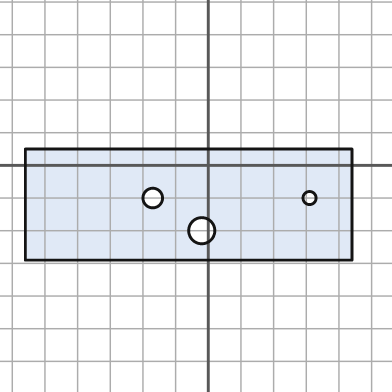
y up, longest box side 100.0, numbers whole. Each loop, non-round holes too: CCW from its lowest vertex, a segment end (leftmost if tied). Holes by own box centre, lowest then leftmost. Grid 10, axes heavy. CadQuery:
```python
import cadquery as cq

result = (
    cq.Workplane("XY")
    .moveTo(-56.0, -29.0)
    .lineTo(44.0, -29.0)
    .lineTo(44.0, 5.0)
    .lineTo(-56.0, 5.0)
    .close()
    .moveTo(-2.0, -20.0)
    .circle(4.0)
    .moveTo(-17.0, -10.0)
    .circle(3.0)
    .moveTo(31.0, -10.0)
    .circle(2.0)
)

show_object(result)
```